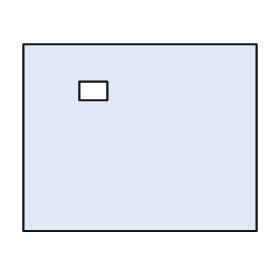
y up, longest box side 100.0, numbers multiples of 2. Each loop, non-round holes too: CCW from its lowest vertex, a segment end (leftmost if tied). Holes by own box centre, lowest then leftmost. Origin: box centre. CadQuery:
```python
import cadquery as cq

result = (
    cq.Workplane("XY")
    .moveTo(-50.0, -40.0)
    .lineTo(50.0, -40.0)
    .lineTo(50.0, 40.0)
    .lineTo(-50.0, 40.0)
    .close()
    .moveTo(-26.0, 16.0)
    .lineTo(-14.0, 16.0)
    .lineTo(-14.0, 24.0)
    .lineTo(-26.0, 24.0)
    .close()
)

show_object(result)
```